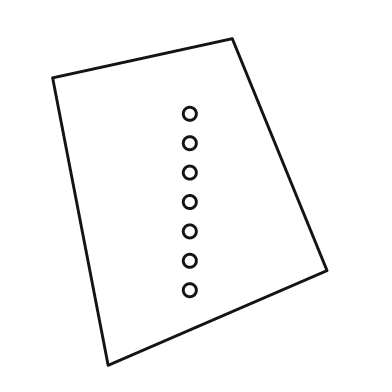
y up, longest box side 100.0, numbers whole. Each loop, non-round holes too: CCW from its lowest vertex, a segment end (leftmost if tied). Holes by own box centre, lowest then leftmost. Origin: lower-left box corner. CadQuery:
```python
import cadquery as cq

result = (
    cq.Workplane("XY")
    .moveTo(17.0, 0.0)
    .lineTo(84.0, 29.0)
    .lineTo(55.0, 100.0)
    .lineTo(0.0, 88.0)
    .close()
    .moveTo(42.0, 23.0)
    .circle(2.0)
    .moveTo(42.0, 32.0)
    .circle(2.0)
    .moveTo(42.0, 41.0)
    .circle(2.0)
    .moveTo(42.0, 50.0)
    .circle(2.0)
    .moveTo(42.0, 59.0)
    .circle(2.0)
    .moveTo(42.0, 68.0)
    .circle(2.0)
    .moveTo(42.0, 77.0)
    .circle(2.0)
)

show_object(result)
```